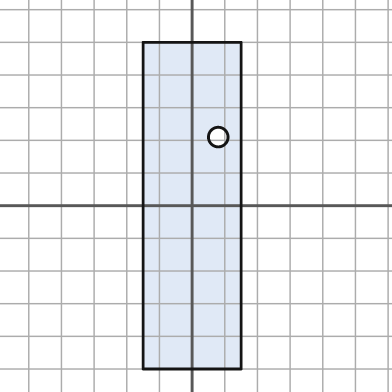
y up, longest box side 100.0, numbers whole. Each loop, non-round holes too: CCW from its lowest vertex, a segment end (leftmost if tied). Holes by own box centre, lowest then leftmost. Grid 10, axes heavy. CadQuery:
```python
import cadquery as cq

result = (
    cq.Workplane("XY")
    .moveTo(-15.0, -50.0)
    .lineTo(15.0, -50.0)
    .lineTo(15.0, 50.0)
    .lineTo(-15.0, 50.0)
    .close()
    .moveTo(8.0, 21.0)
    .circle(3.0)
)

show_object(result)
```